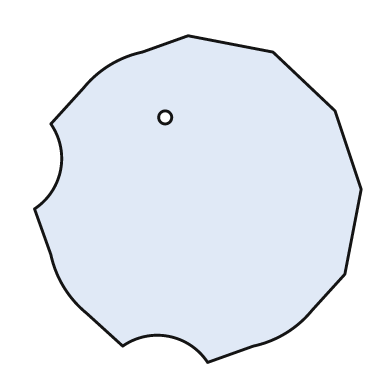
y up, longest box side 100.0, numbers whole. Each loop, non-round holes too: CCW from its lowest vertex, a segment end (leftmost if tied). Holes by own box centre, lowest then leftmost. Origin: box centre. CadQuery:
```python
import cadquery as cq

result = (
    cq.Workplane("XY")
    .moveTo(3.0, -50.0)
    .lineTo(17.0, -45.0)
    .threePointArc((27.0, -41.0), (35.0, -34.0))
    .lineTo(45.0, -23.0)
    .lineTo(50.0, 3.0)
    .lineTo(42.0, 27.0)
    .lineTo(23.0, 45.0)
    .lineTo(-3.0, 50.0)
    .lineTo(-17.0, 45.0)
    .threePointArc((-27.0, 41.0), (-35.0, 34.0))
    .lineTo(-45.0, 23.0)
    .threePointArc((-42.0, 9.0), (-50.0, -3.0))
    .lineTo(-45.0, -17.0)
    .threePointArc((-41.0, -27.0), (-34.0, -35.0))
    .lineTo(-23.0, -45.0)
    .threePointArc((-9.0, -42.0), (3.0, -50.0))
    .close()
    .moveTo(-10.0, 25.0)
    .circle(2.0)
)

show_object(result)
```